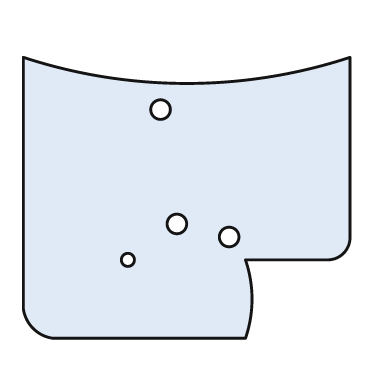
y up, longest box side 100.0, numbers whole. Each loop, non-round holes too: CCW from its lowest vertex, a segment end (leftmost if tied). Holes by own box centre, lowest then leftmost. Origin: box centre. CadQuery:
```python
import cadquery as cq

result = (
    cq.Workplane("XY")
    .moveTo(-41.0, -43.0)
    .lineTo(18.0, -43.0)
    .threePointArc((20.0, -31.0), (18.0, -19.0))
    .lineTo(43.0, -19.0)
    .threePointArc((48.0, -17.0), (50.0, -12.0))
    .lineTo(50.0, 43.0)
    .threePointArc((0.0, 35.0), (-50.0, 43.0))
    .lineTo(-50.0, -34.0)
    .threePointArc((-47.0, -40.0), (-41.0, -43.0))
    .close()
    .moveTo(-18.0, -19.0)
    .circle(2.0)
    .moveTo(13.0, -12.0)
    .circle(3.0)
    .moveTo(-3.0, -8.0)
    .circle(3.0)
    .moveTo(-8.0, 27.0)
    .circle(3.0)
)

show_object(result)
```